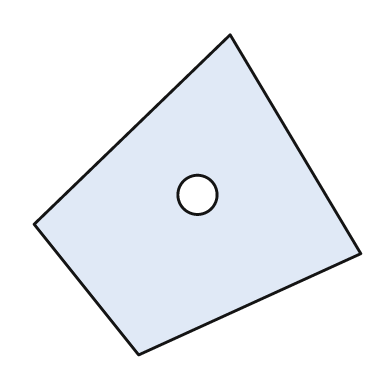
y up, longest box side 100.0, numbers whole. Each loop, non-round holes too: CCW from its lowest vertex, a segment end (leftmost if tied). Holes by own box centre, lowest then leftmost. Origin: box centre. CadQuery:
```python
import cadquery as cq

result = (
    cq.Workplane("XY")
    .moveTo(-18.0, -49.0)
    .lineTo(50.0, -18.0)
    .lineTo(10.0, 49.0)
    .lineTo(-50.0, -9.0)
    .close()
    .moveTo(0.0, 0.0)
    .circle(6.0)
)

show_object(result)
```